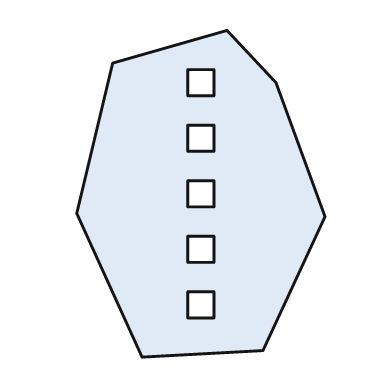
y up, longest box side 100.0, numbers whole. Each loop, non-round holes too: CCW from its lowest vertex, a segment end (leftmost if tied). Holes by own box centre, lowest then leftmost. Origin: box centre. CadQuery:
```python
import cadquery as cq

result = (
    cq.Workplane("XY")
    .moveTo(-18.0, -50.0)
    .lineTo(19.0, -48.0)
    .lineTo(38.0, -7.0)
    .lineTo(23.0, 34.0)
    .lineTo(8.0, 50.0)
    .lineTo(-27.0, 40.0)
    .lineTo(-38.0, -6.0)
    .close()
    .moveTo(-4.0, -38.0)
    .lineTo(4.0, -38.0)
    .lineTo(4.0, -30.0)
    .lineTo(-4.0, -30.0)
    .close()
    .moveTo(-4.0, -21.0)
    .lineTo(4.0, -21.0)
    .lineTo(4.0, -13.0)
    .lineTo(-4.0, -13.0)
    .close()
    .moveTo(-4.0, -4.0)
    .lineTo(4.0, -4.0)
    .lineTo(4.0, 4.0)
    .lineTo(-4.0, 4.0)
    .close()
    .moveTo(-4.0, 13.0)
    .lineTo(4.0, 13.0)
    .lineTo(4.0, 21.0)
    .lineTo(-4.0, 21.0)
    .close()
    .moveTo(-4.0, 30.0)
    .lineTo(4.0, 30.0)
    .lineTo(4.0, 38.0)
    .lineTo(-4.0, 38.0)
    .close()
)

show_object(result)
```